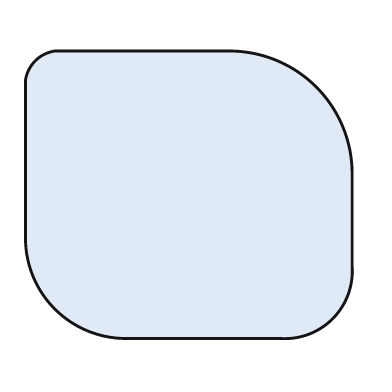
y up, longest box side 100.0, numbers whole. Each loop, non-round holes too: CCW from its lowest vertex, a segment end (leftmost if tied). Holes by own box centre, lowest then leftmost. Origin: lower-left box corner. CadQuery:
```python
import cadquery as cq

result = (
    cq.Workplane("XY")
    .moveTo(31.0, 0.0)
    .lineTo(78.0, 0.0)
    .threePointArc((94.0, 6.0), (100.0, 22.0))
    .lineTo(100.0, 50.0)
    .threePointArc((89.0, 77.0), (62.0, 88.0))
    .lineTo(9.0, 88.0)
    .threePointArc((3.0, 85.0), (0.0, 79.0))
    .lineTo(0.0, 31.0)
    .threePointArc((9.0, 9.0), (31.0, 0.0))
    .close()
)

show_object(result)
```